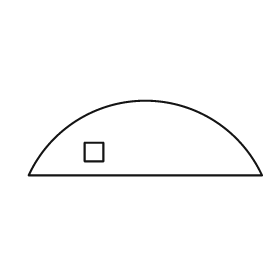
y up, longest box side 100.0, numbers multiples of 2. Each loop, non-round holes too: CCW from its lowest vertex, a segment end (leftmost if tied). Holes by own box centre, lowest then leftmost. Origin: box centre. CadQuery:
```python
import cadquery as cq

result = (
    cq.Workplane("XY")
    .moveTo(-50.0, -16.0)
    .lineTo(50.0, -16.0)
    .threePointArc((0.0, 16.0), (-50.0, -16.0))
    .close()
    .moveTo(-26.0, -10.0)
    .lineTo(-18.0, -10.0)
    .lineTo(-18.0, -2.0)
    .lineTo(-26.0, -2.0)
    .close()
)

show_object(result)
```